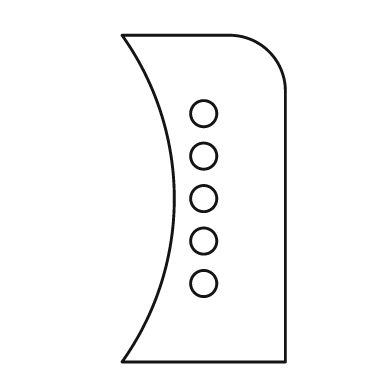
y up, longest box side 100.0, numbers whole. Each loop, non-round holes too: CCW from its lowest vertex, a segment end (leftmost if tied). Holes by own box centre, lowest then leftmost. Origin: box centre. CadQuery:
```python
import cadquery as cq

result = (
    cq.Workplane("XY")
    .moveTo(-25.0, -50.0)
    .lineTo(25.0, -50.0)
    .lineTo(25.0, 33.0)
    .threePointArc((20.0, 45.0), (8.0, 50.0))
    .lineTo(-25.0, 50.0)
    .threePointArc((-9.0, 0.0), (-25.0, -50.0))
    .close()
    .moveTo(0.0, -26.0)
    .circle(4.0)
    .moveTo(0.0, -13.0)
    .circle(4.0)
    .moveTo(0.0, 0.0)
    .circle(4.0)
    .moveTo(0.0, 13.0)
    .circle(4.0)
    .moveTo(0.0, 26.0)
    .circle(4.0)
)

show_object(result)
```